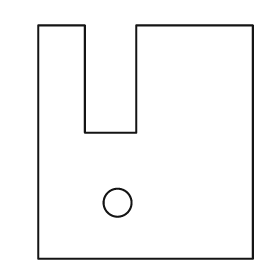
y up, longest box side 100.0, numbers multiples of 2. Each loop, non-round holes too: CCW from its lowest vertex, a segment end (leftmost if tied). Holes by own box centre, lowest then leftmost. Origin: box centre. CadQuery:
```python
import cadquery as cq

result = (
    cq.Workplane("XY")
    .moveTo(-46.0, -50.0)
    .lineTo(46.0, -50.0)
    .lineTo(46.0, 50.0)
    .lineTo(-4.0, 50.0)
    .lineTo(-4.0, 4.0)
    .lineTo(-26.0, 4.0)
    .lineTo(-26.0, 50.0)
    .lineTo(-46.0, 50.0)
    .close()
    .moveTo(-12.0, -26.0)
    .circle(6.0)
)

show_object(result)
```